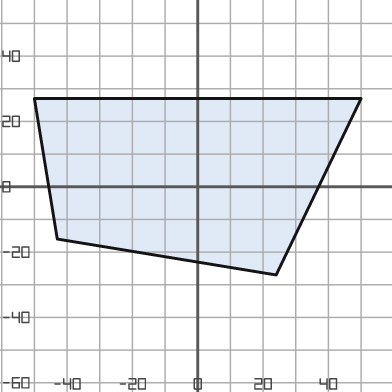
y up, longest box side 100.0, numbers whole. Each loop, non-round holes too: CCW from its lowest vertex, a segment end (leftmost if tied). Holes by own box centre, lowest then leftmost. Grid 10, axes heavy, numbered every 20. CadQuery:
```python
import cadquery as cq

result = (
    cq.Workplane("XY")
    .moveTo(24.0, -27.0)
    .lineTo(50.0, 27.0)
    .lineTo(-50.0, 27.0)
    .lineTo(-43.0, -16.0)
    .close()
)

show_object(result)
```